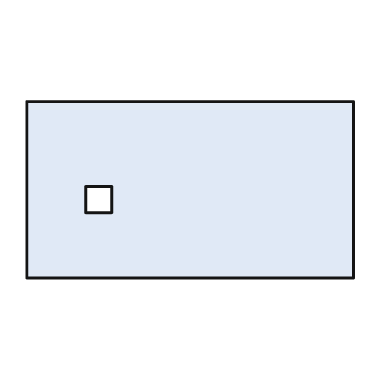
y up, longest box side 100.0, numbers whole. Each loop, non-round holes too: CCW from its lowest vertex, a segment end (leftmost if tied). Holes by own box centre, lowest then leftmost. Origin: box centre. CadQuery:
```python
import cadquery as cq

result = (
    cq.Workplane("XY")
    .moveTo(-50.0, -27.0)
    .lineTo(50.0, -27.0)
    .lineTo(50.0, 27.0)
    .lineTo(-50.0, 27.0)
    .close()
    .moveTo(-32.0, -7.0)
    .lineTo(-24.0, -7.0)
    .lineTo(-24.0, 1.0)
    .lineTo(-32.0, 1.0)
    .close()
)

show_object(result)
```